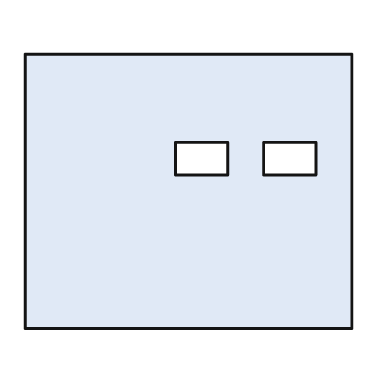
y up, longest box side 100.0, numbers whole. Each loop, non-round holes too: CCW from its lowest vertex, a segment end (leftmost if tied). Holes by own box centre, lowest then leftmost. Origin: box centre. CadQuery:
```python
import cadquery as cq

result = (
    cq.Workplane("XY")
    .moveTo(-50.0, -42.0)
    .lineTo(50.0, -42.0)
    .lineTo(50.0, 42.0)
    .lineTo(-50.0, 42.0)
    .close()
    .moveTo(-4.0, 5.0)
    .lineTo(12.0, 5.0)
    .lineTo(12.0, 15.0)
    .lineTo(-4.0, 15.0)
    .close()
    .moveTo(23.0, 5.0)
    .lineTo(39.0, 5.0)
    .lineTo(39.0, 15.0)
    .lineTo(23.0, 15.0)
    .close()
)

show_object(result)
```